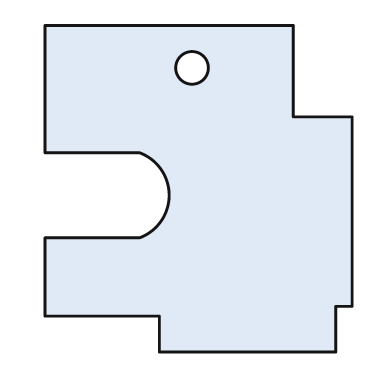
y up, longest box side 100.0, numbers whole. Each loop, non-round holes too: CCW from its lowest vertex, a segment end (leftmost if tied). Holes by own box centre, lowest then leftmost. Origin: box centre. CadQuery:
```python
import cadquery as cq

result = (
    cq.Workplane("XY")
    .moveTo(-12.0, -50.0)
    .lineTo(42.0, -50.0)
    .lineTo(42.0, -36.0)
    .lineTo(47.0, -36.0)
    .lineTo(47.0, 22.0)
    .lineTo(29.0, 22.0)
    .lineTo(29.0, 50.0)
    .lineTo(-47.0, 50.0)
    .lineTo(-47.0, 11.0)
    .lineTo(-18.0, 11.0)
    .threePointArc((-9.0, -2.0), (-18.0, -15.0))
    .lineTo(-47.0, -15.0)
    .lineTo(-47.0, -39.0)
    .lineTo(-12.0, -39.0)
    .close()
    .moveTo(-2.0, 37.0)
    .circle(5.0)
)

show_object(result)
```